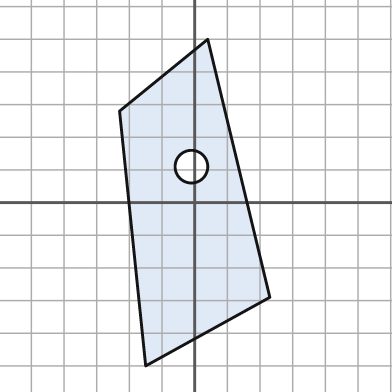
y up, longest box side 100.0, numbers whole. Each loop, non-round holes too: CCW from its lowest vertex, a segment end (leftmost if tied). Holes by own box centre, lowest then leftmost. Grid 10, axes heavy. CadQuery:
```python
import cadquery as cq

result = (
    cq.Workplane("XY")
    .moveTo(-15.0, -50.0)
    .lineTo(23.0, -29.0)
    .lineTo(4.0, 50.0)
    .lineTo(-23.0, 28.0)
    .close()
    .moveTo(-1.0, 11.0)
    .circle(5.0)
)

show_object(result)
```